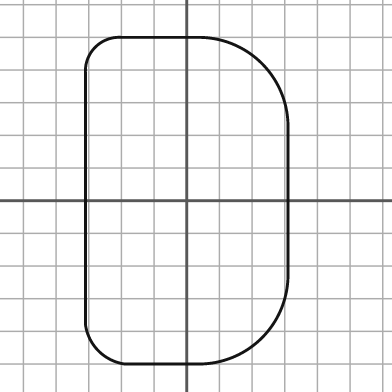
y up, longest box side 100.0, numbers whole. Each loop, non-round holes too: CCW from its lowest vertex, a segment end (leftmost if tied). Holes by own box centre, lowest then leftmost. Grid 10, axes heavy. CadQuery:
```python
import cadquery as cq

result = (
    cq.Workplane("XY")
    .moveTo(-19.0, -50.0)
    .lineTo(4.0, -50.0)
    .threePointArc((23.0, -42.0), (31.0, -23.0))
    .lineTo(31.0, 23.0)
    .threePointArc((23.0, 42.0), (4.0, 50.0))
    .lineTo(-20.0, 50.0)
    .threePointArc((-28.0, 47.0), (-31.0, 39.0))
    .lineTo(-31.0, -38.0)
    .threePointArc((-27.0, -46.0), (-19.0, -50.0))
    .close()
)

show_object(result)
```